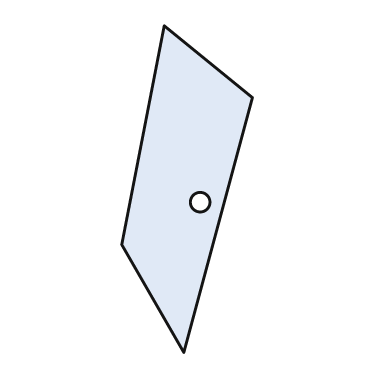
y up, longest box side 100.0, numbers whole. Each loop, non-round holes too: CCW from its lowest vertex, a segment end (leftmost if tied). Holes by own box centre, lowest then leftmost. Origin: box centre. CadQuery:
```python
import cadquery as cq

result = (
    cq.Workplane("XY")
    .moveTo(-1.0, -50.0)
    .lineTo(20.0, 28.0)
    .lineTo(-7.0, 50.0)
    .lineTo(-20.0, -17.0)
    .close()
    .moveTo(4.0, -4.0)
    .circle(3.0)
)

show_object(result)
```